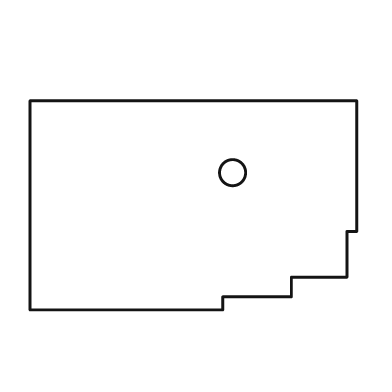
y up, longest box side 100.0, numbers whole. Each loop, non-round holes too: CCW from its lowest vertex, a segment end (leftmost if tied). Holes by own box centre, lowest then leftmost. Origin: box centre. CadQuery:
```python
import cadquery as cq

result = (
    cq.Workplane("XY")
    .moveTo(-50.0, -32.0)
    .lineTo(9.0, -32.0)
    .lineTo(9.0, -28.0)
    .lineTo(30.0, -28.0)
    .lineTo(30.0, -22.0)
    .lineTo(47.0, -22.0)
    .lineTo(47.0, -8.0)
    .lineTo(50.0, -8.0)
    .lineTo(50.0, 32.0)
    .lineTo(-50.0, 32.0)
    .close()
    .moveTo(12.0, 10.0)
    .circle(4.0)
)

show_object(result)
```